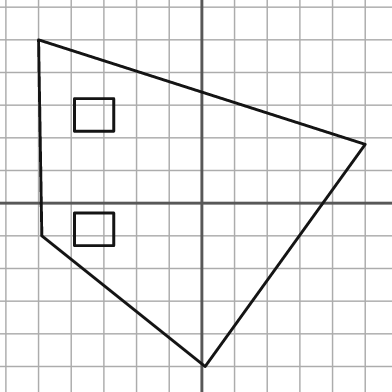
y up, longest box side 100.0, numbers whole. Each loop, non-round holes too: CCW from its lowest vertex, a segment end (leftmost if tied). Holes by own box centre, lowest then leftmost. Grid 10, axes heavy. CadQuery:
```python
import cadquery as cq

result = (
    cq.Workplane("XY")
    .moveTo(1.0, -50.0)
    .lineTo(50.0, 18.0)
    .lineTo(-50.0, 50.0)
    .lineTo(-49.0, -10.0)
    .close()
    .moveTo(-39.0, -13.0)
    .lineTo(-27.0, -13.0)
    .lineTo(-27.0, -3.0)
    .lineTo(-39.0, -3.0)
    .close()
    .moveTo(-39.0, 22.0)
    .lineTo(-27.0, 22.0)
    .lineTo(-27.0, 32.0)
    .lineTo(-39.0, 32.0)
    .close()
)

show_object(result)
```